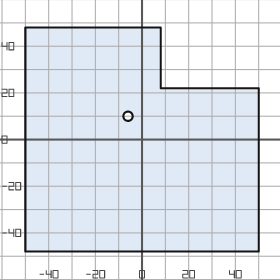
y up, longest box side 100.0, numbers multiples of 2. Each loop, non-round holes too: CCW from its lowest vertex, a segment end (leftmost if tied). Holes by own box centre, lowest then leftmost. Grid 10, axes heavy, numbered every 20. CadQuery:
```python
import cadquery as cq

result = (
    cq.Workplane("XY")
    .moveTo(-50.0, -48.0)
    .lineTo(50.0, -48.0)
    .lineTo(50.0, 22.0)
    .lineTo(8.0, 22.0)
    .lineTo(8.0, 48.0)
    .lineTo(-50.0, 48.0)
    .close()
    .moveTo(-6.0, 10.0)
    .circle(2.0)
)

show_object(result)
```